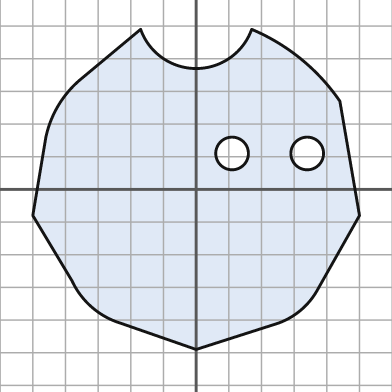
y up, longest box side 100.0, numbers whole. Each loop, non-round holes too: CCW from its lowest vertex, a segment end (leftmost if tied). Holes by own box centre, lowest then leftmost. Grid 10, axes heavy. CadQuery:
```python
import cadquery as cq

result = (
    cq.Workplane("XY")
    .moveTo(0.0, -49.0)
    .lineTo(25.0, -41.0)
    .threePointArc((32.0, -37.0), (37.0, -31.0))
    .lineTo(50.0, -8.0)
    .lineTo(44.0, 27.0)
    .threePointArc((32.0, 40.0), (17.0, 49.0))
    .threePointArc((0.0, 37.0), (-17.0, 49.0))
    .lineTo(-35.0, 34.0)
    .threePointArc((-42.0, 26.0), (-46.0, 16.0))
    .lineTo(-50.0, -8.0)
    .lineTo(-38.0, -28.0)
    .threePointArc((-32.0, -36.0), (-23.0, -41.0))
    .close()
    .moveTo(11.0, 11.0)
    .circle(5.0)
    .moveTo(34.0, 11.0)
    .circle(5.0)
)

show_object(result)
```